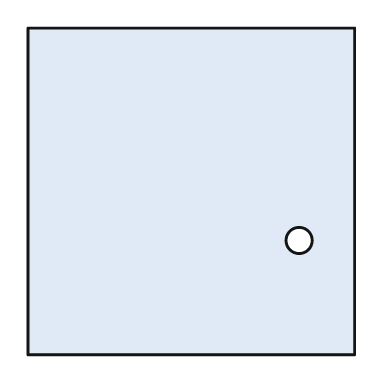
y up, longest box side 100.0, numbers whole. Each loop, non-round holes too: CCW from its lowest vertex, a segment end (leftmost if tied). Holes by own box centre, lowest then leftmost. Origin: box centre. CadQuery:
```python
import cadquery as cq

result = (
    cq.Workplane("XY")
    .moveTo(-50.0, -50.0)
    .lineTo(50.0, -50.0)
    .lineTo(50.0, 50.0)
    .lineTo(-50.0, 50.0)
    .close()
    .moveTo(33.0, -15.0)
    .circle(4.0)
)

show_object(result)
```